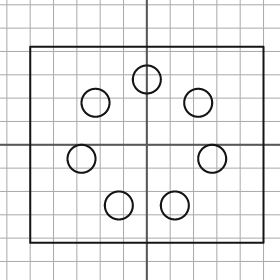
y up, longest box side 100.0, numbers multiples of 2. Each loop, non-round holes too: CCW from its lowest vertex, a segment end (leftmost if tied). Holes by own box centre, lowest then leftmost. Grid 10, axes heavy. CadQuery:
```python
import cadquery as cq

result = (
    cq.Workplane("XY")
    .moveTo(-50.0, -42.0)
    .lineTo(50.0, -42.0)
    .lineTo(50.0, 42.0)
    .lineTo(-50.0, 42.0)
    .close()
    .moveTo(-12.0, -26.0)
    .circle(6.0)
    .moveTo(12.0, -26.0)
    .circle(6.0)
    .moveTo(-28.0, -6.0)
    .circle(6.0)
    .moveTo(28.0, -6.0)
    .circle(6.0)
    .moveTo(-22.0, 18.0)
    .circle(6.0)
    .moveTo(22.0, 18.0)
    .circle(6.0)
    .moveTo(0.0, 28.0)
    .circle(6.0)
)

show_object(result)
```